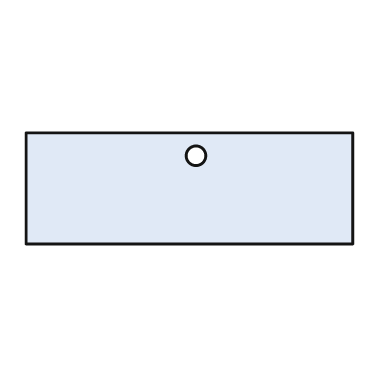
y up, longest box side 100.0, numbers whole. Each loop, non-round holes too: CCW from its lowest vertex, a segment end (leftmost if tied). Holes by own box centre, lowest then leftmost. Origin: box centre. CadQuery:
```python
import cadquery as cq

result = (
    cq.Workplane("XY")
    .moveTo(-50.0, -17.0)
    .lineTo(50.0, -17.0)
    .lineTo(50.0, 17.0)
    .lineTo(-50.0, 17.0)
    .close()
    .moveTo(2.0, 10.0)
    .circle(3.0)
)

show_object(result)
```